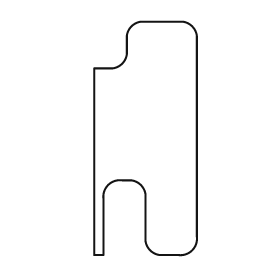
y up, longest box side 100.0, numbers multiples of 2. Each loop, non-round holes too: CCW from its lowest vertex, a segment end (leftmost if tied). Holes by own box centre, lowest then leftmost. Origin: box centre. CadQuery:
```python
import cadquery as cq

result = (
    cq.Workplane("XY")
    .moveTo(-22.0, -50.0)
    .lineTo(-18.0, -50.0)
    .lineTo(-18.0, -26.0)
    .threePointArc((-16.0, -20.0), (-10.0, -18.0))
    .lineTo(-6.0, -18.0)
    .threePointArc((-2.0, -20.0), (0.0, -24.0))
    .lineTo(0.0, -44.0)
    .threePointArc((2.0, -48.0), (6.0, -50.0))
    .lineTo(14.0, -50.0)
    .threePointArc((20.0, -48.0), (22.0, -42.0))
    .lineTo(22.0, 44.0)
    .threePointArc((20.0, 48.0), (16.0, 50.0))
    .lineTo(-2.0, 50.0)
    .threePointArc((-6.0, 48.0), (-8.0, 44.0))
    .lineTo(-8.0, 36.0)
    .threePointArc((-10.0, 32.0), (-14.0, 30.0))
    .lineTo(-22.0, 30.0)
    .close()
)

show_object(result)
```